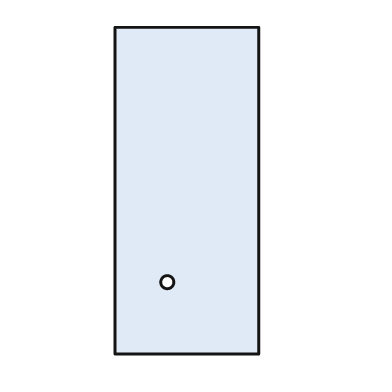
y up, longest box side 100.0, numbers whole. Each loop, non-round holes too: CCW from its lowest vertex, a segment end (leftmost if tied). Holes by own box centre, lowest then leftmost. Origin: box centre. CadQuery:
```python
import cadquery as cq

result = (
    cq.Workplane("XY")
    .moveTo(-22.0, -50.0)
    .lineTo(22.0, -50.0)
    .lineTo(22.0, 50.0)
    .lineTo(-22.0, 50.0)
    .close()
    .moveTo(-6.0, -28.0)
    .circle(2.0)
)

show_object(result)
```